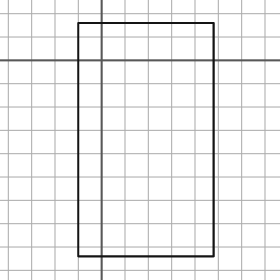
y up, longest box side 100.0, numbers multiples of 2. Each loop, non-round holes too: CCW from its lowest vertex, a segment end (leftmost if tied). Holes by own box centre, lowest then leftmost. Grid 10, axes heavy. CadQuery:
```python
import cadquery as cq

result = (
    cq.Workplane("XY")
    .moveTo(-10.0, -84.0)
    .lineTo(48.0, -84.0)
    .lineTo(48.0, 16.0)
    .lineTo(-10.0, 16.0)
    .close()
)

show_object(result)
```